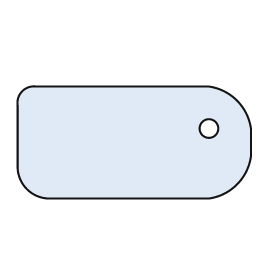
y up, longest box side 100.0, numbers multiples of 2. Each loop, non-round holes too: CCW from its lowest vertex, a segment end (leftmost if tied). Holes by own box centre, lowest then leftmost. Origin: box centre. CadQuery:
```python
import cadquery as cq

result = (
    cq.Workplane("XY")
    .moveTo(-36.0, -24.0)
    .lineTo(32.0, -24.0)
    .threePointArc((44.0, -18.0), (50.0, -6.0))
    .lineTo(50.0, 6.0)
    .threePointArc((44.0, 18.0), (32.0, 24.0))
    .lineTo(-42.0, 24.0)
    .threePointArc((-48.0, 22.0), (-50.0, 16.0))
    .lineTo(-50.0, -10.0)
    .threePointArc((-46.0, -20.0), (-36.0, -24.0))
    .close()
    .moveTo(32.0, 6.0)
    .circle(4.0)
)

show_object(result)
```